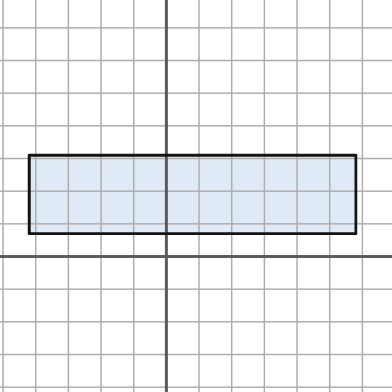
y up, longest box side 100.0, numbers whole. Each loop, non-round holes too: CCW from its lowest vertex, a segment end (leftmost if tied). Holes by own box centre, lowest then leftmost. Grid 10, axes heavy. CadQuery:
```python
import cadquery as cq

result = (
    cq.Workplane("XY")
    .moveTo(-42.0, 7.0)
    .lineTo(58.0, 7.0)
    .lineTo(58.0, 31.0)
    .lineTo(-42.0, 31.0)
    .close()
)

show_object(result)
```